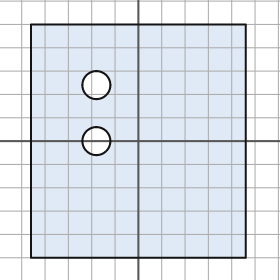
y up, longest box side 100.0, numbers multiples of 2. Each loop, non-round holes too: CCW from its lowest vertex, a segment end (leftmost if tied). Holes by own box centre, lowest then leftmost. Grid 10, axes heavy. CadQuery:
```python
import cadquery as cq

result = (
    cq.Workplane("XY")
    .moveTo(-46.0, -50.0)
    .lineTo(46.0, -50.0)
    .lineTo(46.0, 50.0)
    .lineTo(-46.0, 50.0)
    .close()
    .moveTo(-18.0, 0.0)
    .circle(6.0)
    .moveTo(-18.0, 24.0)
    .circle(6.0)
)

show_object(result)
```